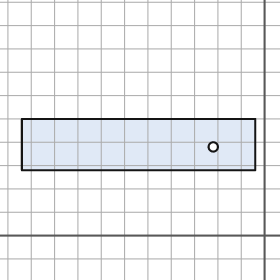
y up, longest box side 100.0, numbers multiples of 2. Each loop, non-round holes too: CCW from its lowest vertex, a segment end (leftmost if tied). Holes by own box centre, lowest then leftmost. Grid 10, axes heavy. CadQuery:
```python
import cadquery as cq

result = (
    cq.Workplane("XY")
    .moveTo(-104.0, 28.0)
    .lineTo(-4.0, 28.0)
    .lineTo(-4.0, 50.0)
    .lineTo(-104.0, 50.0)
    .close()
    .moveTo(-22.0, 38.0)
    .circle(2.0)
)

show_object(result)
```